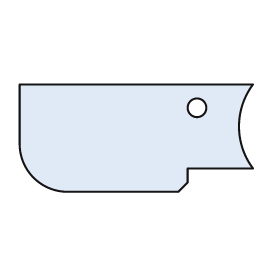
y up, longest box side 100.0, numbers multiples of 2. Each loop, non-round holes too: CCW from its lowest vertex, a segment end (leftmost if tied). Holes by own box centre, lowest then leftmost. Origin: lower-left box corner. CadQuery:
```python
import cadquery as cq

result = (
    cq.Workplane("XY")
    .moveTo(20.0, 0.0)
    .lineTo(68.0, 0.0)
    .lineTo(72.0, 4.0)
    .lineTo(72.0, 10.0)
    .lineTo(100.0, 10.0)
    .threePointArc((94.0, 28.0), (100.0, 46.0))
    .lineTo(0.0, 46.0)
    .lineTo(0.0, 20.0)
    .threePointArc((6.0, 6.0), (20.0, 0.0))
    .close()
    .moveTo(76.0, 36.0)
    .circle(4.0)
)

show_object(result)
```